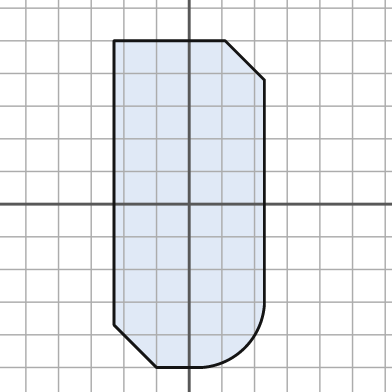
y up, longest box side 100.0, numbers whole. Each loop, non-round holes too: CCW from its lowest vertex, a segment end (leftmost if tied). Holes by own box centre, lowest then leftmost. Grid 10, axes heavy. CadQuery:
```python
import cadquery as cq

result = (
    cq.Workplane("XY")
    .moveTo(-10.0, -50.0)
    .lineTo(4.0, -50.0)
    .threePointArc((17.0, -44.0), (23.0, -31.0))
    .lineTo(23.0, 38.0)
    .lineTo(11.0, 50.0)
    .lineTo(-23.0, 50.0)
    .lineTo(-23.0, -37.0)
    .close()
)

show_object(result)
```